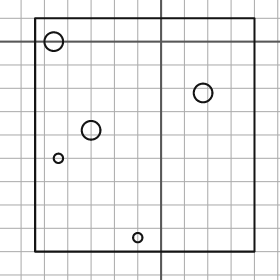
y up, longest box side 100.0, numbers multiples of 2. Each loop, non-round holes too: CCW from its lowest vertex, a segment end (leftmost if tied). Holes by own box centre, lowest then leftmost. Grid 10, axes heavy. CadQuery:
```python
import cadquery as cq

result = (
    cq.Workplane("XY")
    .moveTo(-54.0, -90.0)
    .lineTo(40.0, -90.0)
    .lineTo(40.0, 10.0)
    .lineTo(-54.0, 10.0)
    .close()
    .moveTo(-10.0, -84.0)
    .circle(2.0)
    .moveTo(-44.0, -50.0)
    .circle(2.0)
    .moveTo(-30.0, -38.0)
    .circle(4.0)
    .moveTo(18.0, -22.0)
    .circle(4.0)
    .moveTo(-46.0, 0.0)
    .circle(4.0)
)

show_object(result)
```